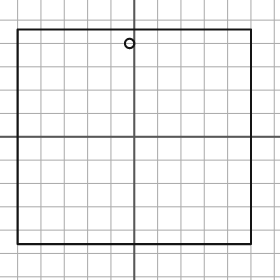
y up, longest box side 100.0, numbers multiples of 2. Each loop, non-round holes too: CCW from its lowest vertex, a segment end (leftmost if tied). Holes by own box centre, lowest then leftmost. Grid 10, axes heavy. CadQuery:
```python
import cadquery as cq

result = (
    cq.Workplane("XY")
    .moveTo(-50.0, -46.0)
    .lineTo(50.0, -46.0)
    .lineTo(50.0, 46.0)
    .lineTo(-50.0, 46.0)
    .close()
    .moveTo(-2.0, 40.0)
    .circle(2.0)
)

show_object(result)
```